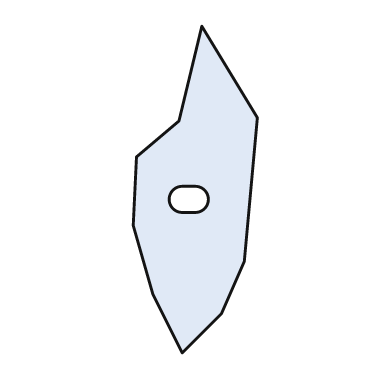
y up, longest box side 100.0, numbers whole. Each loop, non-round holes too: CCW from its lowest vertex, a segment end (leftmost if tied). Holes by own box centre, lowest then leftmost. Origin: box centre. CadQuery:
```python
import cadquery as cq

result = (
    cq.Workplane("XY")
    .moveTo(-4.0, -50.0)
    .lineTo(8.0, -38.0)
    .lineTo(15.0, -22.0)
    .lineTo(19.0, 22.0)
    .lineTo(2.0, 50.0)
    .lineTo(-5.0, 21.0)
    .lineTo(-18.0, 10.0)
    .lineTo(-19.0, -11.0)
    .lineTo(-13.0, -32.0)
    .close()
    .moveTo(-4.0, -7.0)
    .lineTo(0.0, -7.0)
    .threePointArc((4.0, -3.0), (0.0, 1.0))
    .lineTo(-4.0, 1.0)
    .threePointArc((-8.0, -3.0), (-4.0, -7.0))
    .close()
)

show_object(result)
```